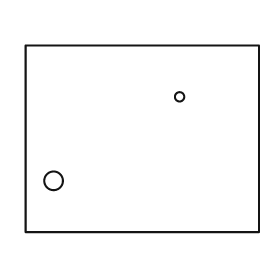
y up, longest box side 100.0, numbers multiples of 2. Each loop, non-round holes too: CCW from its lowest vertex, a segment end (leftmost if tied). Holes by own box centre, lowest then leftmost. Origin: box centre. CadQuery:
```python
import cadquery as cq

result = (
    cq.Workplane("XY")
    .moveTo(-50.0, -40.0)
    .lineTo(50.0, -40.0)
    .lineTo(50.0, 40.0)
    .lineTo(-50.0, 40.0)
    .close()
    .moveTo(-38.0, -18.0)
    .circle(4.0)
    .moveTo(16.0, 18.0)
    .circle(2.0)
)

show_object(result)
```